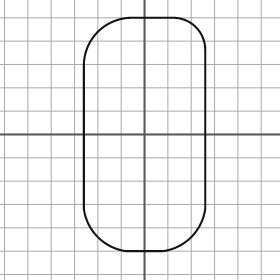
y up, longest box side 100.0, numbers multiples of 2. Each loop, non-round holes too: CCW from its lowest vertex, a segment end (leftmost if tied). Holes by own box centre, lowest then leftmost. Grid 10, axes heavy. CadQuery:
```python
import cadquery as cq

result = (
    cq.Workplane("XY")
    .moveTo(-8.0, -50.0)
    .lineTo(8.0, -50.0)
    .threePointArc((20.0, -44.0), (26.0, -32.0))
    .lineTo(26.0, 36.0)
    .threePointArc((22.0, 46.0), (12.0, 50.0))
    .lineTo(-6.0, 50.0)
    .threePointArc((-20.0, 44.0), (-26.0, 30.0))
    .lineTo(-26.0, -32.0)
    .threePointArc((-20.0, -44.0), (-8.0, -50.0))
    .close()
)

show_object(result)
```